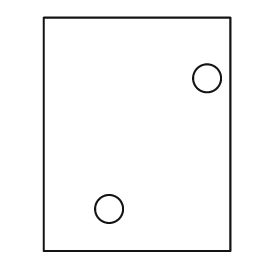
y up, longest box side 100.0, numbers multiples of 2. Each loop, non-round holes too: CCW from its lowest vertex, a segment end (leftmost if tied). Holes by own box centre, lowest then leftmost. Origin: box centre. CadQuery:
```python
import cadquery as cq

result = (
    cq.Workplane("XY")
    .moveTo(-40.0, -50.0)
    .lineTo(40.0, -50.0)
    .lineTo(40.0, 50.0)
    .lineTo(-40.0, 50.0)
    .close()
    .moveTo(-12.0, -32.0)
    .circle(6.0)
    .moveTo(30.0, 24.0)
    .circle(6.0)
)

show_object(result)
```